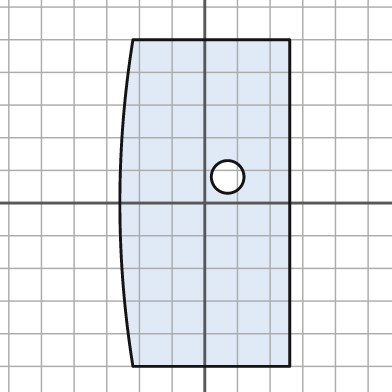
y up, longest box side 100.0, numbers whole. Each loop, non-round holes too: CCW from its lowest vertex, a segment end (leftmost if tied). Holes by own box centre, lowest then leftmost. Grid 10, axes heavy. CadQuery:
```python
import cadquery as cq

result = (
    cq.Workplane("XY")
    .moveTo(-22.0, -50.0)
    .lineTo(26.0, -50.0)
    .lineTo(26.0, 50.0)
    .lineTo(-22.0, 50.0)
    .threePointArc((-26.0, 0.0), (-22.0, -50.0))
    .close()
    .moveTo(7.0, 8.0)
    .circle(5.0)
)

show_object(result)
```